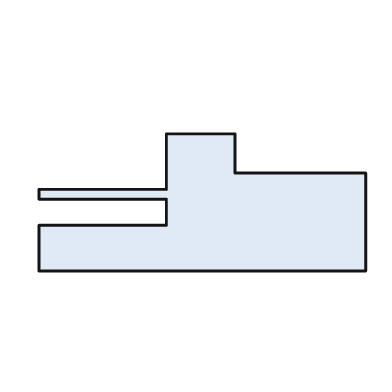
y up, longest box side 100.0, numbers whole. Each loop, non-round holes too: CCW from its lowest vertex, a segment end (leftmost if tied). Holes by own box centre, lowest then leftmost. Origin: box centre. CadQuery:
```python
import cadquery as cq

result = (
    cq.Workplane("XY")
    .moveTo(-50.0, -21.0)
    .lineTo(50.0, -21.0)
    .lineTo(50.0, 9.0)
    .lineTo(10.0, 9.0)
    .lineTo(10.0, 21.0)
    .lineTo(-11.0, 21.0)
    .lineTo(-11.0, 4.0)
    .lineTo(-50.0, 4.0)
    .lineTo(-50.0, 1.0)
    .lineTo(-11.0, 1.0)
    .lineTo(-11.0, -7.0)
    .lineTo(-50.0, -7.0)
    .close()
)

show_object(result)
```